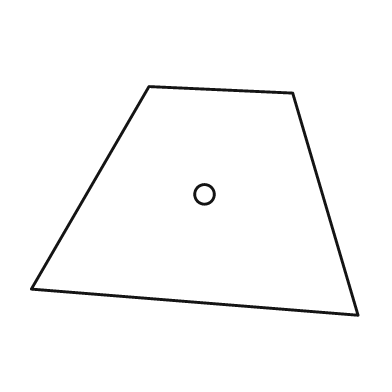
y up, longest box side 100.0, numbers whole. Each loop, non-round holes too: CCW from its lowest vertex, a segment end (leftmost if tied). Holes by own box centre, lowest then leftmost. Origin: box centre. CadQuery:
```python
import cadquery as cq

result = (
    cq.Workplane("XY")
    .moveTo(50.0, -35.0)
    .lineTo(30.0, 33.0)
    .lineTo(-14.0, 35.0)
    .lineTo(-50.0, -27.0)
    .close()
    .moveTo(3.0, 2.0)
    .circle(3.0)
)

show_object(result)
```